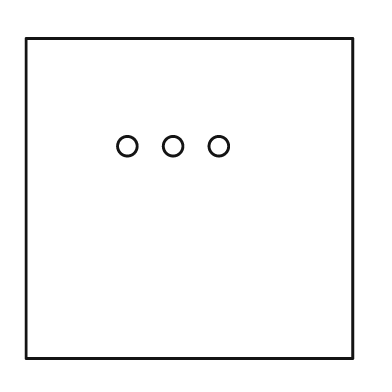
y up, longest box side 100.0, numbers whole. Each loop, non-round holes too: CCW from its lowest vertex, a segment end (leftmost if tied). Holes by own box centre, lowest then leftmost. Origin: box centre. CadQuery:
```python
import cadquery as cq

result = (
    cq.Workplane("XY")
    .moveTo(-50.0, -49.0)
    .lineTo(50.0, -49.0)
    .lineTo(50.0, 49.0)
    .lineTo(-50.0, 49.0)
    .close()
    .moveTo(-19.0, 16.0)
    .circle(3.0)
    .moveTo(-5.0, 16.0)
    .circle(3.0)
    .moveTo(9.0, 16.0)
    .circle(3.0)
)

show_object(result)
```